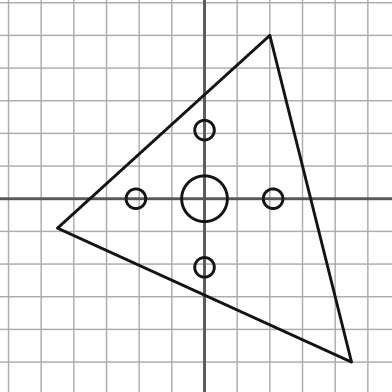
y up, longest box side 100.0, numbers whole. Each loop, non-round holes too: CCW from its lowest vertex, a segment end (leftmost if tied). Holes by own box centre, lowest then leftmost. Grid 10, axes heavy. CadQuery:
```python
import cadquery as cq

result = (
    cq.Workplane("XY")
    .moveTo(45.0, -50.0)
    .lineTo(20.0, 50.0)
    .lineTo(-45.0, -9.0)
    .close()
    .moveTo(0.0, -21.0)
    .circle(3.0)
    .moveTo(-21.0, 0.0)
    .circle(3.0)
    .moveTo(0.0, 0.0)
    .circle(7.0)
    .moveTo(21.0, 0.0)
    .circle(3.0)
    .moveTo(0.0, 21.0)
    .circle(3.0)
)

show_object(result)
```